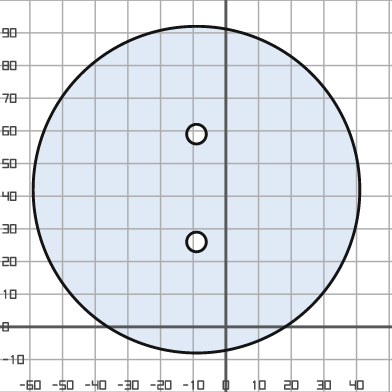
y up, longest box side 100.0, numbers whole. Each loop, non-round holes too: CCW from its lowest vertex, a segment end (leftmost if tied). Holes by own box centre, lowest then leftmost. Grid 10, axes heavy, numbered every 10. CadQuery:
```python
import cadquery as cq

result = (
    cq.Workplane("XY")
    .moveTo(-9.0, 42.0)
    .circle(50.0)
    .moveTo(-9.0, 26.0)
    .circle(3.0)
    .moveTo(-9.0, 59.0)
    .circle(3.0)
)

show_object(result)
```